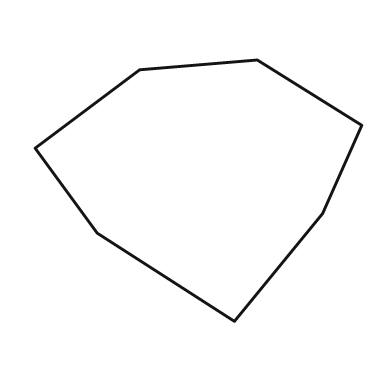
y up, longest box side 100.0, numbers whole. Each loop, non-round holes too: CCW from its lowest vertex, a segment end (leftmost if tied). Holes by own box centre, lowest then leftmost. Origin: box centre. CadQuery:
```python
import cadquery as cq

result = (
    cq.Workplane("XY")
    .moveTo(11.0, -40.0)
    .lineTo(38.0, -7.0)
    .lineTo(50.0, 20.0)
    .lineTo(18.0, 40.0)
    .lineTo(-18.0, 37.0)
    .lineTo(-50.0, 13.0)
    .lineTo(-31.0, -13.0)
    .close()
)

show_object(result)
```